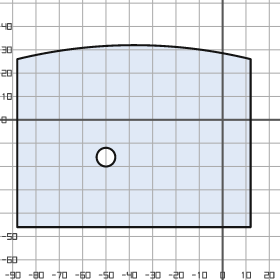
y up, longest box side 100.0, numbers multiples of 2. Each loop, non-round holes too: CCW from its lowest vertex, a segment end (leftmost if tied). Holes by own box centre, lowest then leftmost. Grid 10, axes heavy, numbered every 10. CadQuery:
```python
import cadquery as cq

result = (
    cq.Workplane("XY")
    .moveTo(-88.0, -46.0)
    .lineTo(12.0, -46.0)
    .lineTo(12.0, 26.0)
    .threePointArc((-38.0, 32.0), (-88.0, 26.0))
    .close()
    .moveTo(-50.0, -16.0)
    .circle(4.0)
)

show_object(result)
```